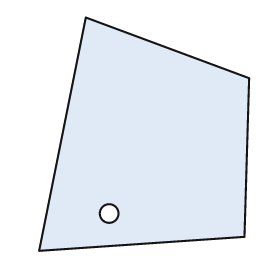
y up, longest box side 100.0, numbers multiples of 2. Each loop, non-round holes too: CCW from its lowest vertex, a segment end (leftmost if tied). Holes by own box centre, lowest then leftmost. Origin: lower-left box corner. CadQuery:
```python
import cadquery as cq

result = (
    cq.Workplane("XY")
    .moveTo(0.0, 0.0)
    .lineTo(88.0, 6.0)
    .lineTo(90.0, 74.0)
    .lineTo(20.0, 100.0)
    .close()
    .moveTo(30.0, 16.0)
    .circle(4.0)
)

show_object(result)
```